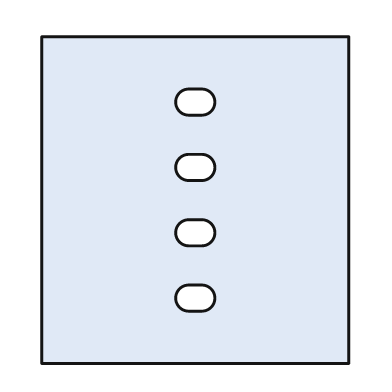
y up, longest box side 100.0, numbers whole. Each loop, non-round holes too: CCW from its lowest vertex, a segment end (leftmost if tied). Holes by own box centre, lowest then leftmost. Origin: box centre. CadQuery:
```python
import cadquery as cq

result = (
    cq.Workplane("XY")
    .moveTo(-47.0, -50.0)
    .lineTo(47.0, -50.0)
    .lineTo(47.0, 50.0)
    .lineTo(-47.0, 50.0)
    .close()
    .moveTo(-2.0, -34.0)
    .lineTo(2.0, -34.0)
    .threePointArc((6.0, -30.0), (2.0, -26.0))
    .lineTo(-2.0, -26.0)
    .threePointArc((-6.0, -30.0), (-2.0, -34.0))
    .close()
    .moveTo(-2.0, -14.0)
    .lineTo(2.0, -14.0)
    .threePointArc((6.0, -10.0), (2.0, -6.0))
    .lineTo(-2.0, -6.0)
    .threePointArc((-6.0, -10.0), (-2.0, -14.0))
    .close()
    .moveTo(-2.0, 6.0)
    .lineTo(2.0, 6.0)
    .threePointArc((6.0, 10.0), (2.0, 14.0))
    .lineTo(-2.0, 14.0)
    .threePointArc((-6.0, 10.0), (-2.0, 6.0))
    .close()
    .moveTo(-2.0, 26.0)
    .lineTo(2.0, 26.0)
    .threePointArc((6.0, 30.0), (2.0, 34.0))
    .lineTo(-2.0, 34.0)
    .threePointArc((-6.0, 30.0), (-2.0, 26.0))
    .close()
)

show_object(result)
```